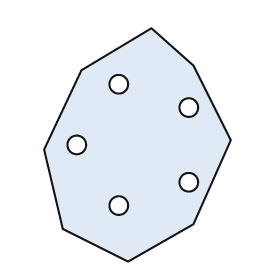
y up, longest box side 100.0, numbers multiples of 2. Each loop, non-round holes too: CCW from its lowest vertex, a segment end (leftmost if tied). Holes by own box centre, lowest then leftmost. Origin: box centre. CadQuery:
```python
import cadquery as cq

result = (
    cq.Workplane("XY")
    .moveTo(-4.0, -50.0)
    .lineTo(24.0, -34.0)
    .lineTo(40.0, 2.0)
    .lineTo(24.0, 34.0)
    .lineTo(6.0, 50.0)
    .lineTo(-24.0, 32.0)
    .lineTo(-40.0, -2.0)
    .lineTo(-32.0, -36.0)
    .close()
    .moveTo(-8.0, -26.0)
    .circle(4.0)
    .moveTo(22.0, -16.0)
    .circle(4.0)
    .moveTo(-26.0, 0.0)
    .circle(4.0)
    .moveTo(22.0, 16.0)
    .circle(4.0)
    .moveTo(-8.0, 26.0)
    .circle(4.0)
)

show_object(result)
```